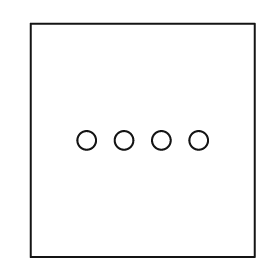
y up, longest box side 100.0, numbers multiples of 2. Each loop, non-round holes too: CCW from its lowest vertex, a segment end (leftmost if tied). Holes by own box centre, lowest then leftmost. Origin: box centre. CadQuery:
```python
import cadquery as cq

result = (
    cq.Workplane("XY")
    .moveTo(-48.0, -50.0)
    .lineTo(48.0, -50.0)
    .lineTo(48.0, 50.0)
    .lineTo(-48.0, 50.0)
    .close()
    .moveTo(-24.0, 0.0)
    .circle(4.0)
    .moveTo(-8.0, 0.0)
    .circle(4.0)
    .moveTo(8.0, 0.0)
    .circle(4.0)
    .moveTo(24.0, 0.0)
    .circle(4.0)
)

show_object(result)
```